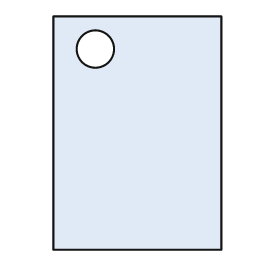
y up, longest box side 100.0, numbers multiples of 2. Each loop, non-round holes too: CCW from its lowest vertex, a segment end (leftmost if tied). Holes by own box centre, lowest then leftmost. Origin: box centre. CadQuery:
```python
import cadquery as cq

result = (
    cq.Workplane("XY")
    .moveTo(-36.0, -50.0)
    .lineTo(36.0, -50.0)
    .lineTo(36.0, 50.0)
    .lineTo(-36.0, 50.0)
    .close()
    .moveTo(-18.0, 36.0)
    .circle(8.0)
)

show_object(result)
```